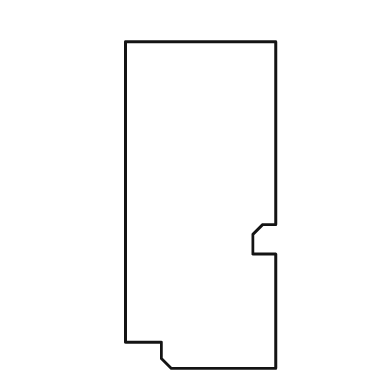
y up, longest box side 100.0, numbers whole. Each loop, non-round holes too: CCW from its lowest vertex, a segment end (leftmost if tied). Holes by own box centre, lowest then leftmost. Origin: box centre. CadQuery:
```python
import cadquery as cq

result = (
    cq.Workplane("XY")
    .moveTo(-9.0, -50.0)
    .lineTo(23.0, -50.0)
    .lineTo(23.0, -15.0)
    .lineTo(16.0, -15.0)
    .lineTo(16.0, -9.0)
    .lineTo(19.0, -6.0)
    .lineTo(23.0, -6.0)
    .lineTo(23.0, 50.0)
    .lineTo(-23.0, 50.0)
    .lineTo(-23.0, -42.0)
    .lineTo(-12.0, -42.0)
    .lineTo(-12.0, -47.0)
    .close()
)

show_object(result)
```